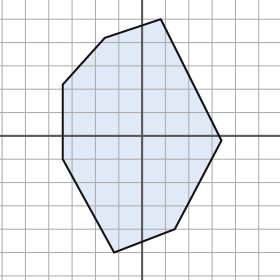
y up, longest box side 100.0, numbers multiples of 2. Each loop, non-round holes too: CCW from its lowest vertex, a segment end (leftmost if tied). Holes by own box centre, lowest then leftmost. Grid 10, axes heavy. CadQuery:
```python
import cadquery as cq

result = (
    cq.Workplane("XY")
    .moveTo(-12.0, -50.0)
    .lineTo(14.0, -40.0)
    .lineTo(34.0, -2.0)
    .lineTo(8.0, 50.0)
    .lineTo(-16.0, 42.0)
    .lineTo(-34.0, 22.0)
    .lineTo(-34.0, -10.0)
    .close()
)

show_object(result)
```